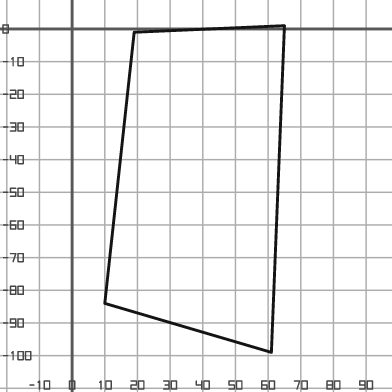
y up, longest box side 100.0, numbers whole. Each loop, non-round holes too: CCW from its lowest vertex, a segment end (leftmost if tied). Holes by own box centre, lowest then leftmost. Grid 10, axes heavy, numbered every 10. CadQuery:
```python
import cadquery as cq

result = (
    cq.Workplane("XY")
    .moveTo(61.0, -99.0)
    .lineTo(65.0, 1.0)
    .lineTo(19.0, -1.0)
    .lineTo(10.0, -84.0)
    .close()
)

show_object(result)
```